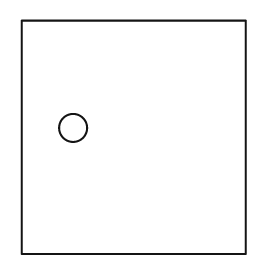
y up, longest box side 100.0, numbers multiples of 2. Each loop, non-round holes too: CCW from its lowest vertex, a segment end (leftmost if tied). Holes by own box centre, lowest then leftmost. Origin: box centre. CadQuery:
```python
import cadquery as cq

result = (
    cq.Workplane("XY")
    .moveTo(-48.0, -50.0)
    .lineTo(48.0, -50.0)
    .lineTo(48.0, 50.0)
    .lineTo(-48.0, 50.0)
    .close()
    .moveTo(-26.0, 4.0)
    .circle(6.0)
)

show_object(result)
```